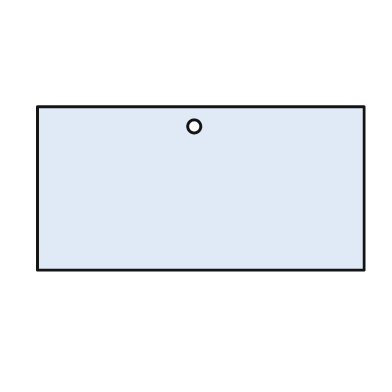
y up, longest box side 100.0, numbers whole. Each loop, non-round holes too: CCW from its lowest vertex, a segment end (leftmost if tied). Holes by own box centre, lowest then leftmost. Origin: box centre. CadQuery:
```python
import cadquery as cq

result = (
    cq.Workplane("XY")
    .moveTo(-50.0, -25.0)
    .lineTo(50.0, -25.0)
    .lineTo(50.0, 25.0)
    .lineTo(-50.0, 25.0)
    .close()
    .moveTo(-2.0, 19.0)
    .circle(2.0)
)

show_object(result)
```